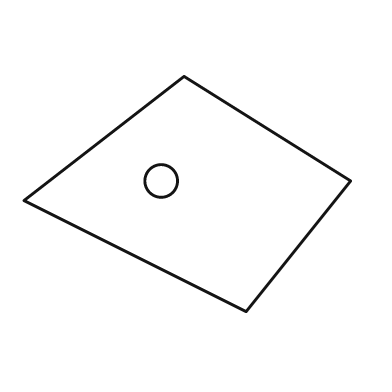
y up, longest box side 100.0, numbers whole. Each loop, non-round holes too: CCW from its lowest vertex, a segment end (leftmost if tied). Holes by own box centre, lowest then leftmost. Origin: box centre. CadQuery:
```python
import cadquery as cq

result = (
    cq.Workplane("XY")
    .moveTo(18.0, -36.0)
    .lineTo(50.0, 4.0)
    .lineTo(-1.0, 36.0)
    .lineTo(-50.0, -2.0)
    .close()
    .moveTo(-8.0, 4.0)
    .circle(5.0)
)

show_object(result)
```